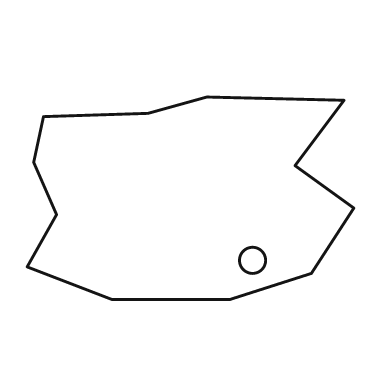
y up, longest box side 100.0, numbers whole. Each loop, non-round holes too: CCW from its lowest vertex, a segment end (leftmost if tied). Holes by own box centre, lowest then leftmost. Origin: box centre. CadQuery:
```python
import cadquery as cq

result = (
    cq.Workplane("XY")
    .moveTo(-24.0, -31.0)
    .lineTo(12.0, -31.0)
    .lineTo(37.0, -23.0)
    .lineTo(50.0, -3.0)
    .lineTo(32.0, 10.0)
    .lineTo(47.0, 30.0)
    .lineTo(5.0, 31.0)
    .lineTo(-13.0, 26.0)
    .lineTo(-45.0, 25.0)
    .lineTo(-48.0, 11.0)
    .lineTo(-41.0, -5.0)
    .lineTo(-50.0, -21.0)
    .close()
    .moveTo(19.0, -19.0)
    .circle(4.0)
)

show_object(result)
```